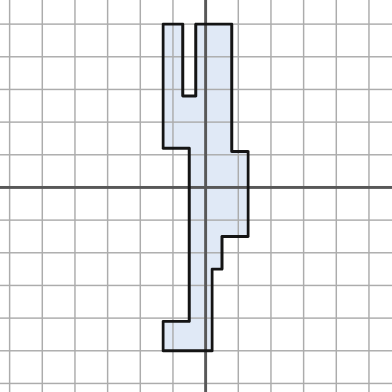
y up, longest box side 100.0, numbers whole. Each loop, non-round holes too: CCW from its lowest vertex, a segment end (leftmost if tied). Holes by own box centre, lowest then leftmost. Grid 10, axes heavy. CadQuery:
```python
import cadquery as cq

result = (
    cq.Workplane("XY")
    .moveTo(-13.0, -50.0)
    .lineTo(2.0, -50.0)
    .lineTo(2.0, -25.0)
    .lineTo(5.0, -25.0)
    .lineTo(5.0, -15.0)
    .lineTo(13.0, -15.0)
    .lineTo(13.0, 11.0)
    .lineTo(8.0, 11.0)
    .lineTo(8.0, 50.0)
    .lineTo(-3.0, 50.0)
    .lineTo(-3.0, 28.0)
    .lineTo(-7.0, 28.0)
    .lineTo(-7.0, 50.0)
    .lineTo(-13.0, 50.0)
    .lineTo(-13.0, 12.0)
    .lineTo(-5.0, 12.0)
    .lineTo(-5.0, -41.0)
    .lineTo(-13.0, -41.0)
    .close()
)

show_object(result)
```